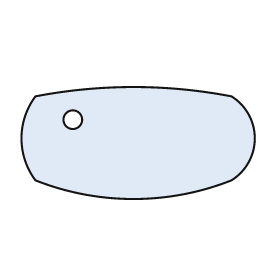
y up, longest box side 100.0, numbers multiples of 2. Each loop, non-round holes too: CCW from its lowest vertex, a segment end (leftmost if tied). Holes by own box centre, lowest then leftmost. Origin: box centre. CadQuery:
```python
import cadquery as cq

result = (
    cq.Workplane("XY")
    .moveTo(-44.0, -16.0)
    .threePointArc((-2.0, -24.0), (40.0, -16.0))
    .threePointArc((50.0, 2.0), (40.0, 20.0))
    .threePointArc((-2.0, 24.0), (-44.0, 20.0))
    .threePointArc((-50.0, 2.0), (-44.0, -16.0))
    .close()
    .moveTo(-28.0, 10.0)
    .circle(4.0)
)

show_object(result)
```